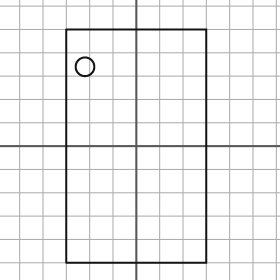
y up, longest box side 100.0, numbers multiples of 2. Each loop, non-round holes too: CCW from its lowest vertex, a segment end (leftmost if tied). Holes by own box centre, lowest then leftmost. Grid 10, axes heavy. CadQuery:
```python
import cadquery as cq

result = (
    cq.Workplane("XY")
    .moveTo(-30.0, -50.0)
    .lineTo(30.0, -50.0)
    .lineTo(30.0, 50.0)
    .lineTo(-30.0, 50.0)
    .close()
    .moveTo(-22.0, 34.0)
    .circle(4.0)
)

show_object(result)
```